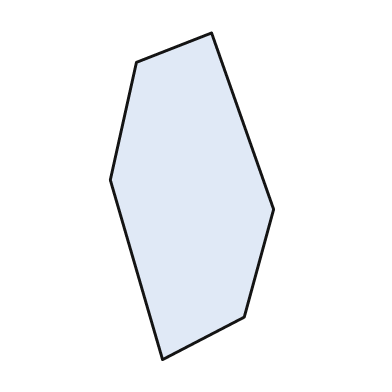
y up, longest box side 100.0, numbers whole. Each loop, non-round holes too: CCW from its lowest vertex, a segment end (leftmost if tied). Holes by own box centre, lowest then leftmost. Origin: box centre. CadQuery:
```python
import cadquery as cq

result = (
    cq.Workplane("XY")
    .moveTo(-9.0, -50.0)
    .lineTo(16.0, -37.0)
    .lineTo(25.0, -4.0)
    .lineTo(6.0, 50.0)
    .lineTo(-17.0, 41.0)
    .lineTo(-25.0, 5.0)
    .close()
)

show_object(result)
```